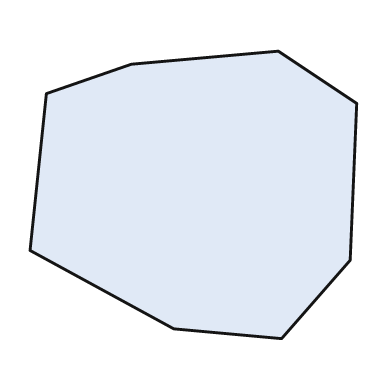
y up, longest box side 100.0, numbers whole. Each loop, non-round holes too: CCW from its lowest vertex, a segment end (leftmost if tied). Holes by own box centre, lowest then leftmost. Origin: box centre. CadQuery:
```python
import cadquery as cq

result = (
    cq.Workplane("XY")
    .moveTo(27.0, -44.0)
    .lineTo(48.0, -20.0)
    .lineTo(50.0, 28.0)
    .lineTo(26.0, 44.0)
    .lineTo(-19.0, 40.0)
    .lineTo(-45.0, 31.0)
    .lineTo(-50.0, -17.0)
    .lineTo(-6.0, -41.0)
    .close()
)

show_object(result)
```